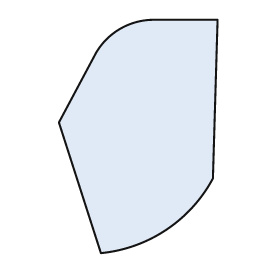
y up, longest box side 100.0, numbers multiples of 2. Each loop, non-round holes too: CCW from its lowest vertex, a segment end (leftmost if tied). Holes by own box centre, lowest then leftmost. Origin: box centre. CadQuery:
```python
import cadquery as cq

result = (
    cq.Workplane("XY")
    .moveTo(-16.0, -50.0)
    .threePointArc((12.0, -40.0), (32.0, -18.0))
    .lineTo(34.0, 50.0)
    .lineTo(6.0, 50.0)
    .threePointArc((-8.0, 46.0), (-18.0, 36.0))
    .lineTo(-34.0, 6.0)
    .close()
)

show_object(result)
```